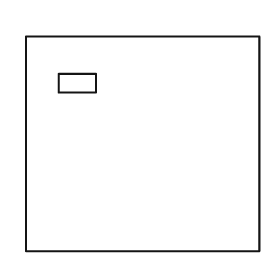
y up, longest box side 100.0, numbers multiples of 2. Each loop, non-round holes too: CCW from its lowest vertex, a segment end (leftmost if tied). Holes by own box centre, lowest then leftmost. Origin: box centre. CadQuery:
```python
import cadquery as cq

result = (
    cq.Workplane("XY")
    .moveTo(-50.0, -46.0)
    .lineTo(50.0, -46.0)
    .lineTo(50.0, 46.0)
    .lineTo(-50.0, 46.0)
    .close()
    .moveTo(-36.0, 22.0)
    .lineTo(-20.0, 22.0)
    .lineTo(-20.0, 30.0)
    .lineTo(-36.0, 30.0)
    .close()
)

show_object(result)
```